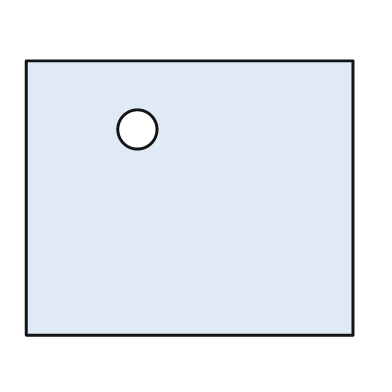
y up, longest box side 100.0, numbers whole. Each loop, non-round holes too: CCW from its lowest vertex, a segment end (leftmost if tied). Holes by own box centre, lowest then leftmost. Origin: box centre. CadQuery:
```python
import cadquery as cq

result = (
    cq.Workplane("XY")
    .moveTo(-50.0, -42.0)
    .lineTo(50.0, -42.0)
    .lineTo(50.0, 42.0)
    .lineTo(-50.0, 42.0)
    .close()
    .moveTo(-16.0, 21.0)
    .circle(6.0)
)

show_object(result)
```